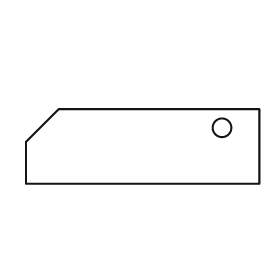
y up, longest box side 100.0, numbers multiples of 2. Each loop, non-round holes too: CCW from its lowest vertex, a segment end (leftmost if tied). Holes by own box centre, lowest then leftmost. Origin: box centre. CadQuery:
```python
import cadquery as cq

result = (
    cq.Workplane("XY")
    .moveTo(-50.0, -16.0)
    .lineTo(50.0, -16.0)
    .lineTo(50.0, 16.0)
    .lineTo(-36.0, 16.0)
    .lineTo(-50.0, 2.0)
    .close()
    .moveTo(34.0, 8.0)
    .circle(4.0)
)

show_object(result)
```